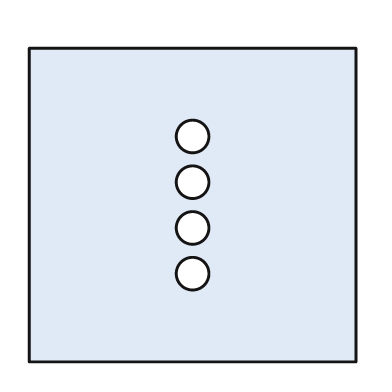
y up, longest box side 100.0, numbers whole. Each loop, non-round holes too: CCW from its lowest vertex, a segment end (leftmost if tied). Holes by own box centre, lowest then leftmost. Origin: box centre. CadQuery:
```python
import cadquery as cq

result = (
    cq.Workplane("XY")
    .moveTo(-50.0, -48.0)
    .lineTo(50.0, -48.0)
    .lineTo(50.0, 48.0)
    .lineTo(-50.0, 48.0)
    .close()
    .moveTo(0.0, -21.0)
    .circle(5.0)
    .moveTo(0.0, -7.0)
    .circle(5.0)
    .moveTo(0.0, 7.0)
    .circle(5.0)
    .moveTo(0.0, 21.0)
    .circle(5.0)
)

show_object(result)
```